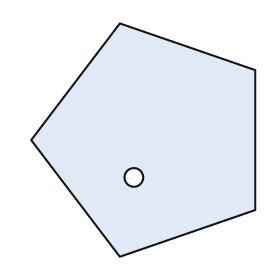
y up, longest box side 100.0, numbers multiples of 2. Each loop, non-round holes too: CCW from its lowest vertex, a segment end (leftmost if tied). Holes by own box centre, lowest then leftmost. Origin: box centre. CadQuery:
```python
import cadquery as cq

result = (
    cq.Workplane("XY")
    .moveTo(-10.0, -50.0)
    .lineTo(48.0, -30.0)
    .lineTo(48.0, 30.0)
    .lineTo(-10.0, 50.0)
    .lineTo(-48.0, 0.0)
    .close()
    .moveTo(-4.0, -16.0)
    .circle(4.0)
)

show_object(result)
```